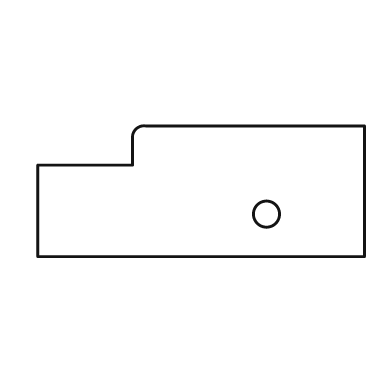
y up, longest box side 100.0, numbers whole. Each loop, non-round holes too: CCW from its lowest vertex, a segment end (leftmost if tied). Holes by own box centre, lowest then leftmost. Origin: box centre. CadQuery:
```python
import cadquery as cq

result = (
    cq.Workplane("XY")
    .moveTo(-50.0, -20.0)
    .lineTo(50.0, -20.0)
    .lineTo(50.0, 20.0)
    .lineTo(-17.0, 20.0)
    .threePointArc((-20.0, 19.0), (-21.0, 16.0))
    .lineTo(-21.0, 8.0)
    .lineTo(-50.0, 8.0)
    .close()
    .moveTo(20.0, -7.0)
    .circle(4.0)
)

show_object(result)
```